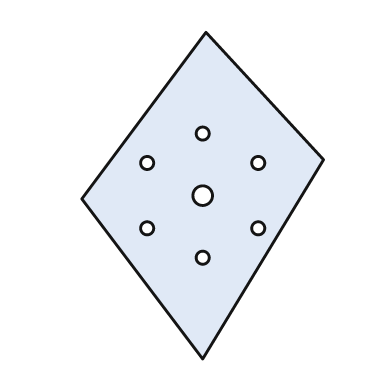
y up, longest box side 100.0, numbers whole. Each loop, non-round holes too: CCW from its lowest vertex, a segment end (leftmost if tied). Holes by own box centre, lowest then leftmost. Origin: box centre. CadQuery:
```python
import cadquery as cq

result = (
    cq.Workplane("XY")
    .moveTo(0.0, -50.0)
    .lineTo(37.0, 11.0)
    .lineTo(1.0, 50.0)
    .lineTo(-37.0, -1.0)
    .close()
    .moveTo(0.0, -19.0)
    .circle(2.0)
    .moveTo(-17.0, -10.0)
    .circle(2.0)
    .moveTo(17.0, -10.0)
    .circle(2.0)
    .moveTo(0.0, 0.0)
    .circle(3.0)
    .moveTo(-17.0, 10.0)
    .circle(2.0)
    .moveTo(17.0, 10.0)
    .circle(2.0)
    .moveTo(0.0, 19.0)
    .circle(2.0)
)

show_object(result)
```